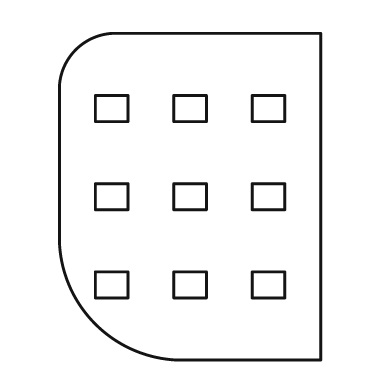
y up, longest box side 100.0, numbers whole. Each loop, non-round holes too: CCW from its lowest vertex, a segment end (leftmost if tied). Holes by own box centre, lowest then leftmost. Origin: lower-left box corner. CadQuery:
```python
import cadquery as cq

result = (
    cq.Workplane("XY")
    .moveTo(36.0, 0.0)
    .lineTo(80.0, 0.0)
    .lineTo(80.0, 100.0)
    .lineTo(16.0, 100.0)
    .threePointArc((5.0, 95.0), (0.0, 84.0))
    .lineTo(0.0, 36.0)
    .threePointArc((11.0, 11.0), (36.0, 0.0))
    .close()
    .moveTo(11.0, 19.0)
    .lineTo(21.0, 19.0)
    .lineTo(21.0, 27.0)
    .lineTo(11.0, 27.0)
    .close()
    .moveTo(35.0, 19.0)
    .lineTo(45.0, 19.0)
    .lineTo(45.0, 27.0)
    .lineTo(35.0, 27.0)
    .close()
    .moveTo(59.0, 19.0)
    .lineTo(69.0, 19.0)
    .lineTo(69.0, 27.0)
    .lineTo(59.0, 27.0)
    .close()
    .moveTo(11.0, 46.0)
    .lineTo(21.0, 46.0)
    .lineTo(21.0, 54.0)
    .lineTo(11.0, 54.0)
    .close()
    .moveTo(35.0, 46.0)
    .lineTo(45.0, 46.0)
    .lineTo(45.0, 54.0)
    .lineTo(35.0, 54.0)
    .close()
    .moveTo(59.0, 46.0)
    .lineTo(69.0, 46.0)
    .lineTo(69.0, 54.0)
    .lineTo(59.0, 54.0)
    .close()
    .moveTo(11.0, 73.0)
    .lineTo(21.0, 73.0)
    .lineTo(21.0, 81.0)
    .lineTo(11.0, 81.0)
    .close()
    .moveTo(35.0, 73.0)
    .lineTo(45.0, 73.0)
    .lineTo(45.0, 81.0)
    .lineTo(35.0, 81.0)
    .close()
    .moveTo(59.0, 73.0)
    .lineTo(69.0, 73.0)
    .lineTo(69.0, 81.0)
    .lineTo(59.0, 81.0)
    .close()
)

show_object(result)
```